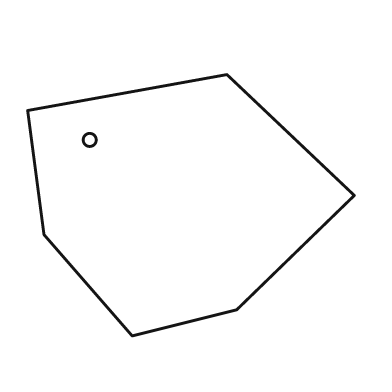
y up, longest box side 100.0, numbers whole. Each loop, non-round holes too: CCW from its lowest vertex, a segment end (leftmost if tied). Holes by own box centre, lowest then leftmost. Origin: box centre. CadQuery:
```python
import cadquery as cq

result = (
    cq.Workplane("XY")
    .moveTo(-18.0, -40.0)
    .lineTo(14.0, -32.0)
    .lineTo(50.0, 3.0)
    .lineTo(11.0, 40.0)
    .lineTo(-50.0, 29.0)
    .lineTo(-45.0, -9.0)
    .close()
    .moveTo(-31.0, 20.0)
    .circle(2.0)
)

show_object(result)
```